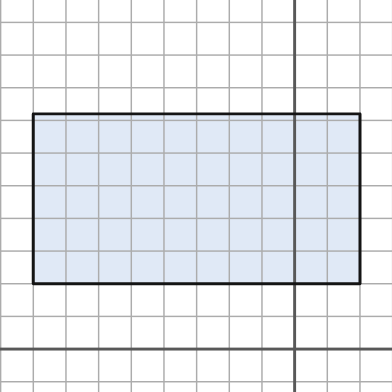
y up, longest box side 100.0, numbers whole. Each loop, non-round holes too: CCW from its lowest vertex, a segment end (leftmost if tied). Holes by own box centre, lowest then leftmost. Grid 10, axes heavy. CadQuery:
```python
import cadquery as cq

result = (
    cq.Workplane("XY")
    .moveTo(-80.0, 20.0)
    .lineTo(20.0, 20.0)
    .lineTo(20.0, 72.0)
    .lineTo(-80.0, 72.0)
    .close()
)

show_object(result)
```